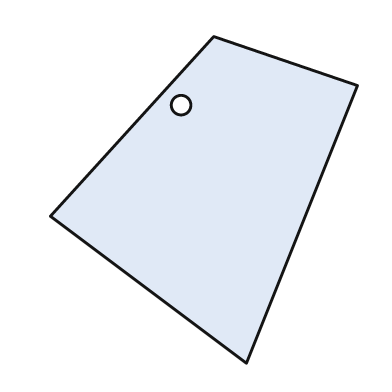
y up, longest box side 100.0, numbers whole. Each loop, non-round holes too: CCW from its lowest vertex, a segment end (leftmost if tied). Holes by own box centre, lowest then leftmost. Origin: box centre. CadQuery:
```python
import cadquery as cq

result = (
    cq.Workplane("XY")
    .moveTo(13.0, -50.0)
    .lineTo(47.0, 35.0)
    .lineTo(3.0, 50.0)
    .lineTo(-47.0, -5.0)
    .close()
    .moveTo(-7.0, 29.0)
    .circle(3.0)
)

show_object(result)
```